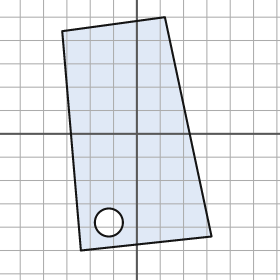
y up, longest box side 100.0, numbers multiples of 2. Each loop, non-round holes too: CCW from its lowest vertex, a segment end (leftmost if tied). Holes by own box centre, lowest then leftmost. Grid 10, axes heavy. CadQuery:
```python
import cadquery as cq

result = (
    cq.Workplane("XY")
    .moveTo(-24.0, -50.0)
    .lineTo(32.0, -44.0)
    .lineTo(12.0, 50.0)
    .lineTo(-32.0, 44.0)
    .close()
    .moveTo(-12.0, -38.0)
    .circle(6.0)
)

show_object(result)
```